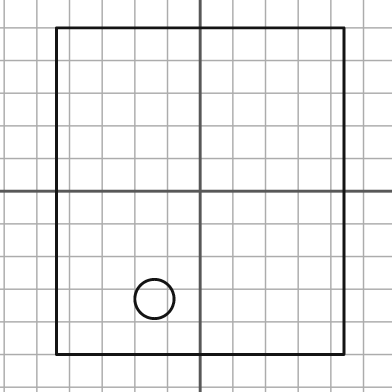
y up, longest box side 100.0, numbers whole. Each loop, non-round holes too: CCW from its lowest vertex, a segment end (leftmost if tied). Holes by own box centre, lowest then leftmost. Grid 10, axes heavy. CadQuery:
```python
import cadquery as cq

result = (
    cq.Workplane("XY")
    .moveTo(-44.0, -50.0)
    .lineTo(44.0, -50.0)
    .lineTo(44.0, 50.0)
    .lineTo(-44.0, 50.0)
    .close()
    .moveTo(-14.0, -33.0)
    .circle(6.0)
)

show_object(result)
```